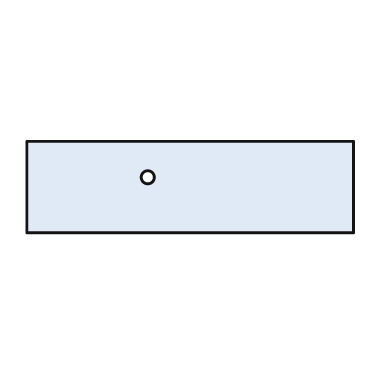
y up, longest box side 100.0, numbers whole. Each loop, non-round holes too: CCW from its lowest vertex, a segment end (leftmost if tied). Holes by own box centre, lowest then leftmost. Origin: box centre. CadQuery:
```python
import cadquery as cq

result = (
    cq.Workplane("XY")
    .moveTo(-50.0, -14.0)
    .lineTo(50.0, -14.0)
    .lineTo(50.0, 14.0)
    .lineTo(-50.0, 14.0)
    .close()
    .moveTo(-13.0, 3.0)
    .circle(2.0)
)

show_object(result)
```